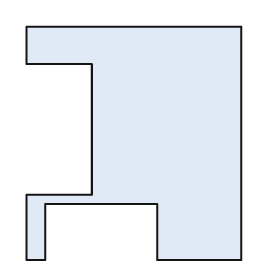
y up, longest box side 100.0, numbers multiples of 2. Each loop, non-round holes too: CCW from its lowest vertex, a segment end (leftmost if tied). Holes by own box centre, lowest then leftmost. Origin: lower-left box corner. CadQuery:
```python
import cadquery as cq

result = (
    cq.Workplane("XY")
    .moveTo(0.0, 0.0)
    .lineTo(8.0, 0.0)
    .lineTo(8.0, 24.0)
    .lineTo(56.0, 24.0)
    .lineTo(56.0, 0.0)
    .lineTo(92.0, 0.0)
    .lineTo(92.0, 100.0)
    .lineTo(0.0, 100.0)
    .lineTo(0.0, 84.0)
    .lineTo(28.0, 84.0)
    .lineTo(28.0, 28.0)
    .lineTo(0.0, 28.0)
    .close()
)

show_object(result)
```